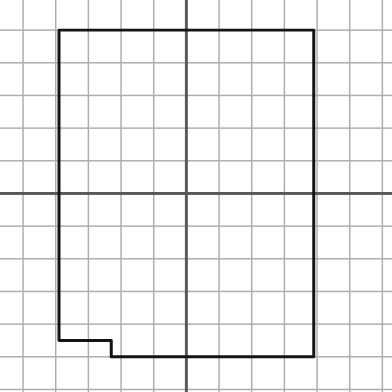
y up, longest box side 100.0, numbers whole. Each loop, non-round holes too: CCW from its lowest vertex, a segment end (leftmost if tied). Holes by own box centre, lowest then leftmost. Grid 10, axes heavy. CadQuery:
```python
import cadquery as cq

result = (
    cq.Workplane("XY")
    .moveTo(-23.0, -50.0)
    .lineTo(39.0, -50.0)
    .lineTo(39.0, 50.0)
    .lineTo(-39.0, 50.0)
    .lineTo(-39.0, -45.0)
    .lineTo(-23.0, -45.0)
    .close()
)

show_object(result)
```